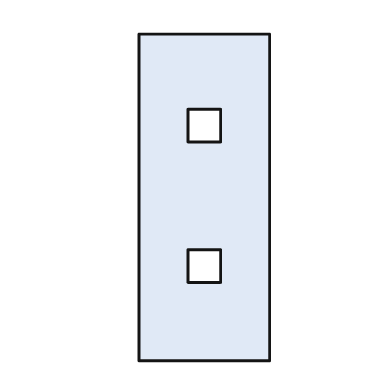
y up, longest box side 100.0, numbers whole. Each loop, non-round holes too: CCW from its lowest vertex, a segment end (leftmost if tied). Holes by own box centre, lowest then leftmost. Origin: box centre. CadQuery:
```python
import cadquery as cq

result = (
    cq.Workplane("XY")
    .moveTo(-20.0, -50.0)
    .lineTo(20.0, -50.0)
    .lineTo(20.0, 50.0)
    .lineTo(-20.0, 50.0)
    .close()
    .moveTo(-5.0, -26.0)
    .lineTo(5.0, -26.0)
    .lineTo(5.0, -16.0)
    .lineTo(-5.0, -16.0)
    .close()
    .moveTo(-5.0, 17.0)
    .lineTo(5.0, 17.0)
    .lineTo(5.0, 27.0)
    .lineTo(-5.0, 27.0)
    .close()
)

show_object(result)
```